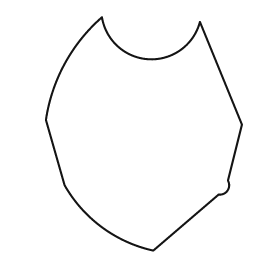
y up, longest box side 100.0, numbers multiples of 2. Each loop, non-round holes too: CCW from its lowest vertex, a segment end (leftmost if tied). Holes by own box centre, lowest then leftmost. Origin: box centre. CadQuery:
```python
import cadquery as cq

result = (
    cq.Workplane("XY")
    .moveTo(4.0, -50.0)
    .lineTo(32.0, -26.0)
    .threePointArc((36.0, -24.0), (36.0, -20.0))
    .lineTo(42.0, 4.0)
    .lineTo(24.0, 48.0)
    .threePointArc((2.0, 32.0), (-18.0, 50.0))
    .threePointArc((-34.0, 30.0), (-42.0, 6.0))
    .lineTo(-34.0, -22.0)
    .threePointArc((-18.0, -40.0), (4.0, -50.0))
    .close()
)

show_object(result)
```